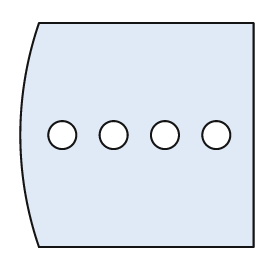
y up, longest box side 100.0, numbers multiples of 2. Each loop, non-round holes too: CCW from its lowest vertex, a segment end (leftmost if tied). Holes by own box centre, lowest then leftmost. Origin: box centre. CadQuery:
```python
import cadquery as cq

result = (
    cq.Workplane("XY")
    .moveTo(-42.0, -48.0)
    .lineTo(50.0, -48.0)
    .lineTo(50.0, 48.0)
    .lineTo(-42.0, 48.0)
    .threePointArc((-50.0, 0.0), (-42.0, -48.0))
    .close()
    .moveTo(-32.0, 0.0)
    .circle(6.0)
    .moveTo(-10.0, 0.0)
    .circle(6.0)
    .moveTo(12.0, 0.0)
    .circle(6.0)
    .moveTo(34.0, 0.0)
    .circle(6.0)
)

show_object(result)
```